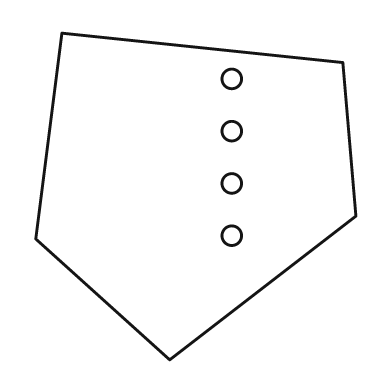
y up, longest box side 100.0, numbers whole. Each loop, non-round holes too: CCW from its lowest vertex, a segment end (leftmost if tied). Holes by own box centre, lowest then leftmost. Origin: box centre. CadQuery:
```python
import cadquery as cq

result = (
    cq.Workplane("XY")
    .moveTo(-8.0, -50.0)
    .lineTo(49.0, -6.0)
    .lineTo(45.0, 41.0)
    .lineTo(-41.0, 50.0)
    .lineTo(-49.0, -13.0)
    .close()
    .moveTo(11.0, -12.0)
    .circle(3.0)
    .moveTo(11.0, 4.0)
    .circle(3.0)
    .moveTo(11.0, 20.0)
    .circle(3.0)
    .moveTo(11.0, 36.0)
    .circle(3.0)
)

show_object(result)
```